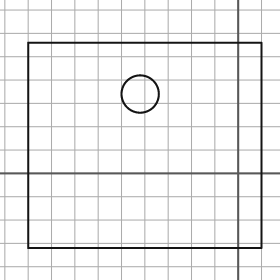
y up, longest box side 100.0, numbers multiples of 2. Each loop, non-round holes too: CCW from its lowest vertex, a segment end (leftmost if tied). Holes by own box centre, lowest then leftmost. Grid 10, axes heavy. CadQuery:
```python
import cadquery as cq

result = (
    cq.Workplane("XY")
    .moveTo(-90.0, -32.0)
    .lineTo(10.0, -32.0)
    .lineTo(10.0, 56.0)
    .lineTo(-90.0, 56.0)
    .close()
    .moveTo(-42.0, 34.0)
    .circle(8.0)
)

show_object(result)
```